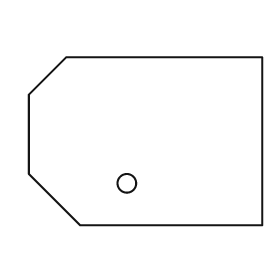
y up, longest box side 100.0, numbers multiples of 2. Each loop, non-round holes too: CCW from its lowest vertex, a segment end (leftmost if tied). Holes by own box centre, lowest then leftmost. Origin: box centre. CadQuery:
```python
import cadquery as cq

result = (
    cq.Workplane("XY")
    .moveTo(-28.0, -36.0)
    .lineTo(50.0, -36.0)
    .lineTo(50.0, 36.0)
    .lineTo(-34.0, 36.0)
    .lineTo(-50.0, 20.0)
    .lineTo(-50.0, -14.0)
    .close()
    .moveTo(-8.0, -18.0)
    .circle(4.0)
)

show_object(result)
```